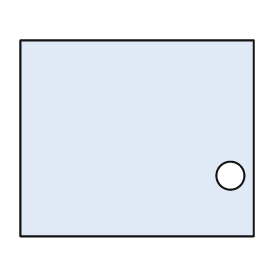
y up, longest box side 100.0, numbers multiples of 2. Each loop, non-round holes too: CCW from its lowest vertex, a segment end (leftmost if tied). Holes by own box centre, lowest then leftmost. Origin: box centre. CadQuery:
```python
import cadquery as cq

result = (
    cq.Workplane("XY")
    .moveTo(-50.0, -42.0)
    .lineTo(50.0, -42.0)
    .lineTo(50.0, 42.0)
    .lineTo(-50.0, 42.0)
    .close()
    .moveTo(40.0, -16.0)
    .circle(6.0)
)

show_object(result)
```